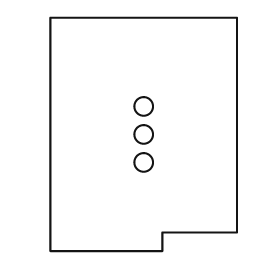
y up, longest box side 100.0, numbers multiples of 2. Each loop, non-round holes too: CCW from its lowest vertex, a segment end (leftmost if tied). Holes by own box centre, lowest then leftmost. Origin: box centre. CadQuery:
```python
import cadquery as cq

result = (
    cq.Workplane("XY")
    .moveTo(-40.0, -50.0)
    .lineTo(8.0, -50.0)
    .lineTo(8.0, -42.0)
    .lineTo(40.0, -42.0)
    .lineTo(40.0, 50.0)
    .lineTo(-40.0, 50.0)
    .close()
    .moveTo(0.0, -12.0)
    .circle(4.0)
    .moveTo(0.0, 0.0)
    .circle(4.0)
    .moveTo(0.0, 12.0)
    .circle(4.0)
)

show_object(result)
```